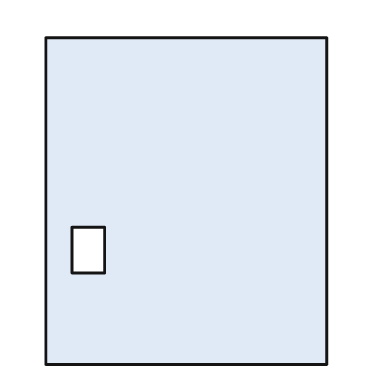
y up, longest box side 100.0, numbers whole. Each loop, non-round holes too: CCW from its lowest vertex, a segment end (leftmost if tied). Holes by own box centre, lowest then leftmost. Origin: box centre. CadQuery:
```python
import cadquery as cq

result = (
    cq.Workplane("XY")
    .moveTo(-43.0, -50.0)
    .lineTo(43.0, -50.0)
    .lineTo(43.0, 50.0)
    .lineTo(-43.0, 50.0)
    .close()
    .moveTo(-35.0, -22.0)
    .lineTo(-25.0, -22.0)
    .lineTo(-25.0, -8.0)
    .lineTo(-35.0, -8.0)
    .close()
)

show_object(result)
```